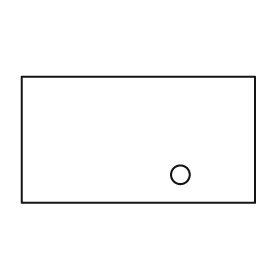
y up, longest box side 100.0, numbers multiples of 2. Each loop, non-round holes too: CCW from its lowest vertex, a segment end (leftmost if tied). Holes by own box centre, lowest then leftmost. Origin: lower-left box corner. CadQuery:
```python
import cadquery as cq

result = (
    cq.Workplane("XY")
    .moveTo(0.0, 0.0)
    .lineTo(100.0, 0.0)
    .lineTo(100.0, 54.0)
    .lineTo(0.0, 54.0)
    .close()
    .moveTo(68.0, 12.0)
    .circle(4.0)
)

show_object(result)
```